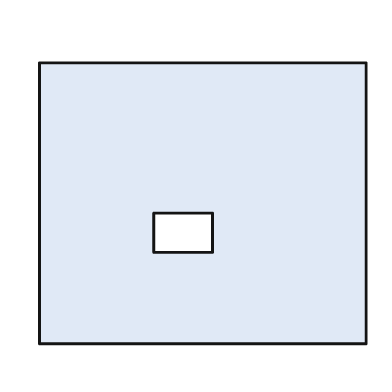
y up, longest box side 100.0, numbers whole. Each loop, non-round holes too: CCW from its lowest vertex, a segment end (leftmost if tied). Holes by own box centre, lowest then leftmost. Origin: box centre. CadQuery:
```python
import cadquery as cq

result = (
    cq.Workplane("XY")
    .moveTo(-50.0, -43.0)
    .lineTo(50.0, -43.0)
    .lineTo(50.0, 43.0)
    .lineTo(-50.0, 43.0)
    .close()
    .moveTo(-15.0, -15.0)
    .lineTo(3.0, -15.0)
    .lineTo(3.0, -3.0)
    .lineTo(-15.0, -3.0)
    .close()
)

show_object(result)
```